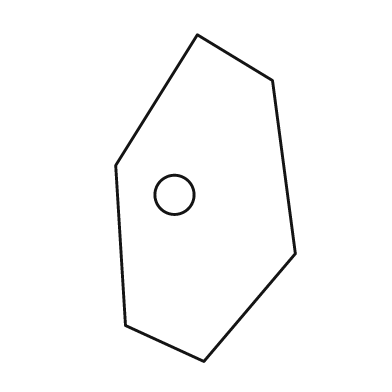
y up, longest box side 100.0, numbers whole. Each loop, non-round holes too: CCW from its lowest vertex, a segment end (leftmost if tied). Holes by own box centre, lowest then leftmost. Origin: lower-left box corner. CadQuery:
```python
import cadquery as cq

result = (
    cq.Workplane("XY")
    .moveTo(27.0, 0.0)
    .lineTo(55.0, 33.0)
    .lineTo(48.0, 86.0)
    .lineTo(25.0, 100.0)
    .lineTo(0.0, 60.0)
    .lineTo(3.0, 11.0)
    .close()
    .moveTo(18.0, 51.0)
    .circle(6.0)
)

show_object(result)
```